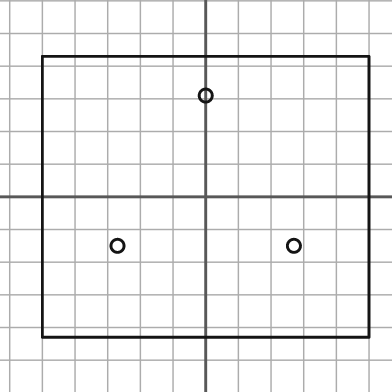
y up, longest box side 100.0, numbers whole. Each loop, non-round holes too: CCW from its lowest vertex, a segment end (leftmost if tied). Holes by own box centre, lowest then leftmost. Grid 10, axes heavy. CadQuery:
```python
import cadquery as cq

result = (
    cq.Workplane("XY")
    .moveTo(-50.0, -43.0)
    .lineTo(50.0, -43.0)
    .lineTo(50.0, 43.0)
    .lineTo(-50.0, 43.0)
    .close()
    .moveTo(-27.0, -15.0)
    .circle(2.0)
    .moveTo(27.0, -15.0)
    .circle(2.0)
    .moveTo(0.0, 31.0)
    .circle(2.0)
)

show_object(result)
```